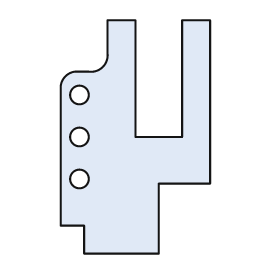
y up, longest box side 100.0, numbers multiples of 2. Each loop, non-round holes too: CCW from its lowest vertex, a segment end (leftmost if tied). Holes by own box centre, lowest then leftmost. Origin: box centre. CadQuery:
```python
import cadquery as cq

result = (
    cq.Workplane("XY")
    .moveTo(-22.0, -50.0)
    .lineTo(10.0, -50.0)
    .lineTo(10.0, -20.0)
    .lineTo(32.0, -20.0)
    .lineTo(32.0, 50.0)
    .lineTo(20.0, 50.0)
    .lineTo(20.0, 0.0)
    .lineTo(0.0, 0.0)
    .lineTo(0.0, 50.0)
    .lineTo(-12.0, 50.0)
    .lineTo(-12.0, 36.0)
    .threePointArc((-14.0, 30.0), (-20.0, 28.0))
    .lineTo(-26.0, 28.0)
    .threePointArc((-30.0, 26.0), (-32.0, 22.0))
    .lineTo(-32.0, -38.0)
    .lineTo(-22.0, -38.0)
    .close()
    .moveTo(-24.0, -18.0)
    .circle(4.0)
    .moveTo(-24.0, 0.0)
    .circle(4.0)
    .moveTo(-24.0, 18.0)
    .circle(4.0)
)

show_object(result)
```